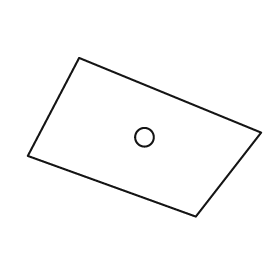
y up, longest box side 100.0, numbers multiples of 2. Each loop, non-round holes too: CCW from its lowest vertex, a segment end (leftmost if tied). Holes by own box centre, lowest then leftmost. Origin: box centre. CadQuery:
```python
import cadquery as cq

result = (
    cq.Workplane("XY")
    .moveTo(22.0, -34.0)
    .lineTo(50.0, 2.0)
    .lineTo(-28.0, 34.0)
    .lineTo(-50.0, -8.0)
    .close()
    .moveTo(0.0, 0.0)
    .circle(4.0)
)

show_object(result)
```